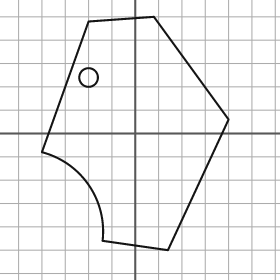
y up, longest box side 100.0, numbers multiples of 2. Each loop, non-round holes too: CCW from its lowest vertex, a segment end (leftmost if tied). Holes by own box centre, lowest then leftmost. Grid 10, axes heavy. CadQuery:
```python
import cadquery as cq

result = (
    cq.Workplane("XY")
    .moveTo(14.0, -50.0)
    .lineTo(40.0, 6.0)
    .lineTo(8.0, 50.0)
    .lineTo(-20.0, 48.0)
    .lineTo(-40.0, -8.0)
    .threePointArc((-20.0, -22.0), (-14.0, -46.0))
    .close()
    .moveTo(-20.0, 24.0)
    .circle(4.0)
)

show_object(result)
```